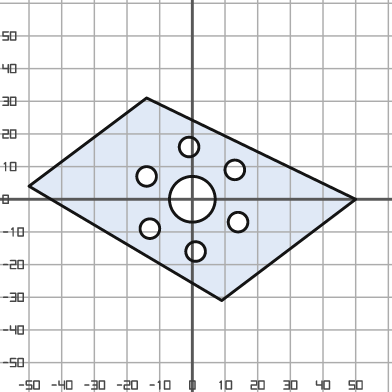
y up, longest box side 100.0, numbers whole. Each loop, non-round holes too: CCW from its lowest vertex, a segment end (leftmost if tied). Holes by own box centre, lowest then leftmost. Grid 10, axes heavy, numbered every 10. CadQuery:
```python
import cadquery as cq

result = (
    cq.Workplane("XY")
    .moveTo(9.0, -31.0)
    .lineTo(50.0, 0.0)
    .lineTo(-14.0, 31.0)
    .lineTo(-50.0, 4.0)
    .close()
    .moveTo(1.0, -16.0)
    .circle(3.0)
    .moveTo(-13.0, -9.0)
    .circle(3.0)
    .moveTo(14.0, -7.0)
    .circle(3.0)
    .moveTo(0.0, 0.0)
    .circle(7.0)
    .moveTo(-14.0, 7.0)
    .circle(3.0)
    .moveTo(13.0, 9.0)
    .circle(3.0)
    .moveTo(-1.0, 16.0)
    .circle(3.0)
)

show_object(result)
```